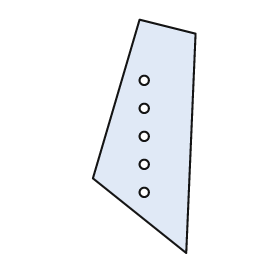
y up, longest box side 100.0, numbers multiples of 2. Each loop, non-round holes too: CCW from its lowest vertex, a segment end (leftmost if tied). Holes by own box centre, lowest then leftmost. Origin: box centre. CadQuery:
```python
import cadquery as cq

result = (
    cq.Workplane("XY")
    .moveTo(18.0, -50.0)
    .lineTo(22.0, 44.0)
    .lineTo(-2.0, 50.0)
    .lineTo(-22.0, -18.0)
    .close()
    .moveTo(0.0, -24.0)
    .circle(2.0)
    .moveTo(0.0, -12.0)
    .circle(2.0)
    .moveTo(0.0, 0.0)
    .circle(2.0)
    .moveTo(0.0, 12.0)
    .circle(2.0)
    .moveTo(0.0, 24.0)
    .circle(2.0)
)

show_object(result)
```